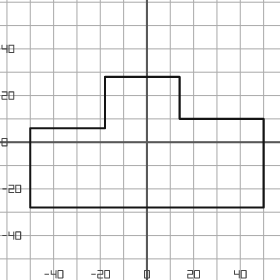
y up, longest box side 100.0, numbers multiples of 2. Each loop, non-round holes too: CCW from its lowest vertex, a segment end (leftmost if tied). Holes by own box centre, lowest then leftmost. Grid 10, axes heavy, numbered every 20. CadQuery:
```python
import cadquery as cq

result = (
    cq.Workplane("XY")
    .moveTo(-50.0, -28.0)
    .lineTo(50.0, -28.0)
    .lineTo(50.0, 10.0)
    .lineTo(14.0, 10.0)
    .lineTo(14.0, 28.0)
    .lineTo(-18.0, 28.0)
    .lineTo(-18.0, 6.0)
    .lineTo(-50.0, 6.0)
    .close()
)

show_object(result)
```